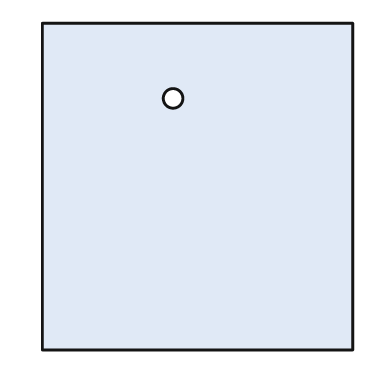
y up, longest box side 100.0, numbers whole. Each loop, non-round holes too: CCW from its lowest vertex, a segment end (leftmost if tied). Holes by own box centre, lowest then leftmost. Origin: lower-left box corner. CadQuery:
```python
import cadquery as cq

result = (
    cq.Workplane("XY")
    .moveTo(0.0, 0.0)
    .lineTo(95.0, 0.0)
    .lineTo(95.0, 100.0)
    .lineTo(0.0, 100.0)
    .close()
    .moveTo(40.0, 77.0)
    .circle(3.0)
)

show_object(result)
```